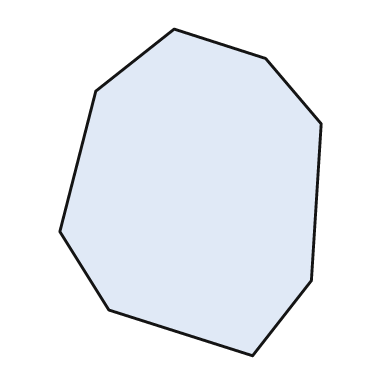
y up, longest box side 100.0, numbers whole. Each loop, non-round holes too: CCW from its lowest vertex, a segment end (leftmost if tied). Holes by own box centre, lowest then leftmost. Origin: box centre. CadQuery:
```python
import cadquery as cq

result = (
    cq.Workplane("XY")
    .moveTo(19.0, -50.0)
    .lineTo(37.0, -27.0)
    .lineTo(40.0, 21.0)
    .lineTo(23.0, 41.0)
    .lineTo(-5.0, 50.0)
    .lineTo(-29.0, 31.0)
    .lineTo(-40.0, -12.0)
    .lineTo(-25.0, -36.0)
    .close()
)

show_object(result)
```